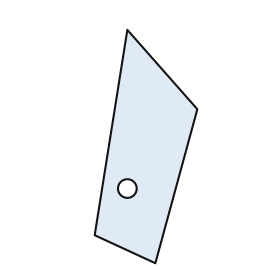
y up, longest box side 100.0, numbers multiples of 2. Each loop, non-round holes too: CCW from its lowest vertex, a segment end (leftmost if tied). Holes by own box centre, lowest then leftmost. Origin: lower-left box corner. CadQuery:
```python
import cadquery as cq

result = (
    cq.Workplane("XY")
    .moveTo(26.0, 0.0)
    .lineTo(44.0, 66.0)
    .lineTo(14.0, 100.0)
    .lineTo(0.0, 12.0)
    .close()
    .moveTo(14.0, 32.0)
    .circle(4.0)
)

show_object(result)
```